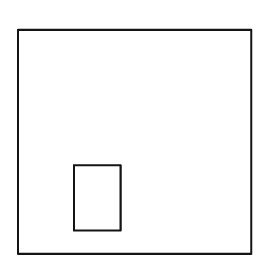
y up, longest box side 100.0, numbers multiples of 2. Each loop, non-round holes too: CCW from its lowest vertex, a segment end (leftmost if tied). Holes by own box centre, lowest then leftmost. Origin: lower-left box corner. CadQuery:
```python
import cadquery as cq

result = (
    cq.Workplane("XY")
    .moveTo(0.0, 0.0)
    .lineTo(100.0, 0.0)
    .lineTo(100.0, 96.0)
    .lineTo(0.0, 96.0)
    .close()
    .moveTo(24.0, 10.0)
    .lineTo(44.0, 10.0)
    .lineTo(44.0, 38.0)
    .lineTo(24.0, 38.0)
    .close()
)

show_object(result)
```